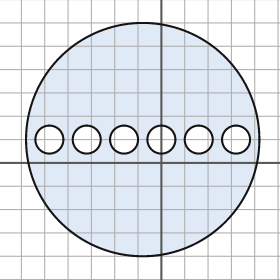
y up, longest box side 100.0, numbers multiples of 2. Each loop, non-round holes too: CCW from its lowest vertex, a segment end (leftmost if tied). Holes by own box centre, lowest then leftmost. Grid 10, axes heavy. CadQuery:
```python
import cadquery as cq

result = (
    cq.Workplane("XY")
    .moveTo(-8.0, 10.0)
    .circle(50.0)
    .moveTo(-48.0, 10.0)
    .circle(6.0)
    .moveTo(-32.0, 10.0)
    .circle(6.0)
    .moveTo(-16.0, 10.0)
    .circle(6.0)
    .moveTo(0.0, 10.0)
    .circle(6.0)
    .moveTo(16.0, 10.0)
    .circle(6.0)
    .moveTo(32.0, 10.0)
    .circle(6.0)
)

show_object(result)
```